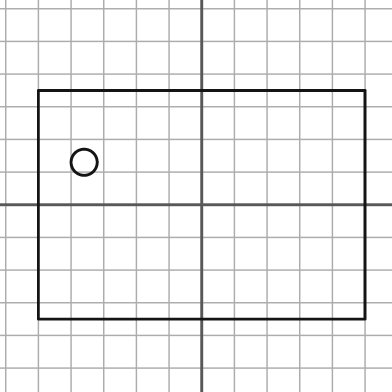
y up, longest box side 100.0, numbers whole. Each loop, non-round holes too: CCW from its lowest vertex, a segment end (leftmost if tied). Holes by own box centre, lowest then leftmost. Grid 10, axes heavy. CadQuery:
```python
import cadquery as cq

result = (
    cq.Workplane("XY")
    .moveTo(-50.0, -35.0)
    .lineTo(50.0, -35.0)
    .lineTo(50.0, 35.0)
    .lineTo(-50.0, 35.0)
    .close()
    .moveTo(-36.0, 13.0)
    .circle(4.0)
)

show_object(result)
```